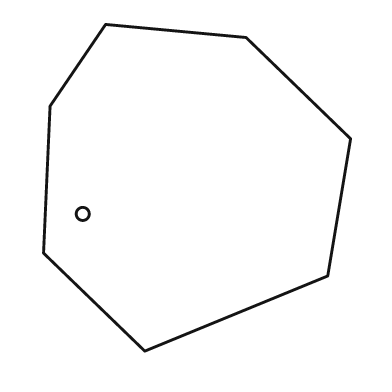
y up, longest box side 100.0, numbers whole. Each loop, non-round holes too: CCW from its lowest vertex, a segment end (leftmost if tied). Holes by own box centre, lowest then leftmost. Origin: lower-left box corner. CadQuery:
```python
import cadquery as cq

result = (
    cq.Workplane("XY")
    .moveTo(31.0, 0.0)
    .lineTo(87.0, 23.0)
    .lineTo(94.0, 65.0)
    .lineTo(62.0, 96.0)
    .lineTo(19.0, 100.0)
    .lineTo(2.0, 75.0)
    .lineTo(0.0, 30.0)
    .close()
    .moveTo(12.0, 42.0)
    .circle(2.0)
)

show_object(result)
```